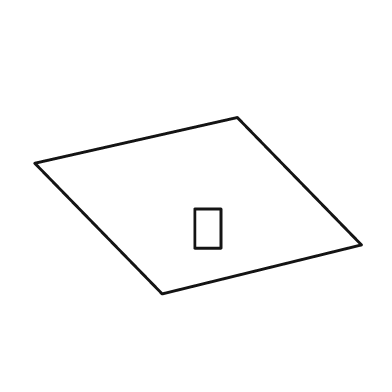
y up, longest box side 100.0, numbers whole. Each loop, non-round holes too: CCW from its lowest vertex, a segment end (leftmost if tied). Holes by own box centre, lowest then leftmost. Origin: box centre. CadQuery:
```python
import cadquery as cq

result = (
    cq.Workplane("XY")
    .moveTo(-11.0, -27.0)
    .lineTo(50.0, -12.0)
    .lineTo(12.0, 27.0)
    .lineTo(-50.0, 13.0)
    .close()
    .moveTo(-1.0, -13.0)
    .lineTo(7.0, -13.0)
    .lineTo(7.0, -1.0)
    .lineTo(-1.0, -1.0)
    .close()
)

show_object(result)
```